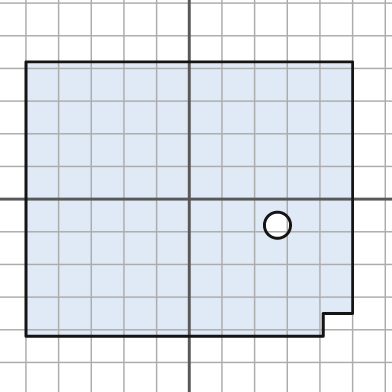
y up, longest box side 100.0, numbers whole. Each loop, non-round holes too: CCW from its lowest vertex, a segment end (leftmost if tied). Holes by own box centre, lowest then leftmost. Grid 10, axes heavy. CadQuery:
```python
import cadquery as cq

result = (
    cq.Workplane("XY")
    .moveTo(-50.0, -42.0)
    .lineTo(41.0, -42.0)
    .lineTo(41.0, -35.0)
    .lineTo(50.0, -35.0)
    .lineTo(50.0, 42.0)
    .lineTo(-50.0, 42.0)
    .close()
    .moveTo(27.0, -8.0)
    .circle(4.0)
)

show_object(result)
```